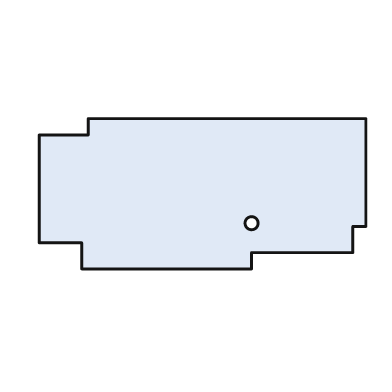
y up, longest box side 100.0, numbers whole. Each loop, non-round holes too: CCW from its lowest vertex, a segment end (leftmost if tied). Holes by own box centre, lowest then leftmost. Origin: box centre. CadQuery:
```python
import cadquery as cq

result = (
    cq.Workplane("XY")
    .moveTo(-37.0, -23.0)
    .lineTo(15.0, -23.0)
    .lineTo(15.0, -18.0)
    .lineTo(46.0, -18.0)
    .lineTo(46.0, -10.0)
    .lineTo(50.0, -10.0)
    .lineTo(50.0, 23.0)
    .lineTo(-35.0, 23.0)
    .lineTo(-35.0, 18.0)
    .lineTo(-50.0, 18.0)
    .lineTo(-50.0, -15.0)
    .lineTo(-37.0, -15.0)
    .close()
    .moveTo(15.0, -9.0)
    .circle(2.0)
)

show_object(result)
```